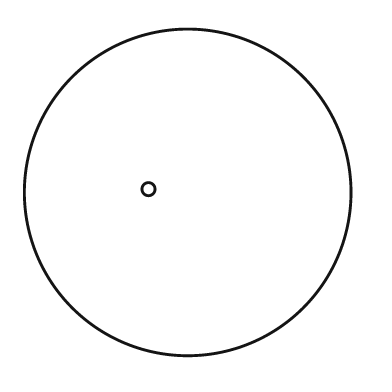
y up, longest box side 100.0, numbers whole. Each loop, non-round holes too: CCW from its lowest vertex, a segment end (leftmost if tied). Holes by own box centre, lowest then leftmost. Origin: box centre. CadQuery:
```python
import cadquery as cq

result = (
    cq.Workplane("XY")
    .moveTo(0.0, 0.0)
    .circle(50.0)
    .moveTo(-12.0, 1.0)
    .circle(2.0)
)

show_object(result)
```